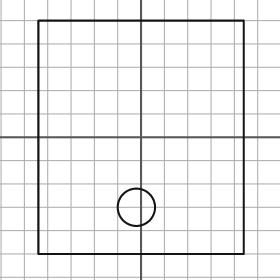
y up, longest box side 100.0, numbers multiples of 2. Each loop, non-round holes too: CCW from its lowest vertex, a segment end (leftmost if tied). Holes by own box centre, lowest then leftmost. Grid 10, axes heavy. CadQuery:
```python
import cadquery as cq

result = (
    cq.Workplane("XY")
    .moveTo(-44.0, -50.0)
    .lineTo(44.0, -50.0)
    .lineTo(44.0, 50.0)
    .lineTo(-44.0, 50.0)
    .close()
    .moveTo(-2.0, -30.0)
    .circle(8.0)
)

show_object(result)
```